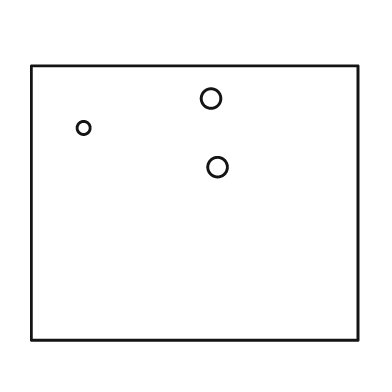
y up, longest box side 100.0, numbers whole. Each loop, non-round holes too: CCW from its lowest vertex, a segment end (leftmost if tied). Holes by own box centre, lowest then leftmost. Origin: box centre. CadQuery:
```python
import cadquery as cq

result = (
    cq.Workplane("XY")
    .moveTo(-50.0, -42.0)
    .lineTo(50.0, -42.0)
    .lineTo(50.0, 42.0)
    .lineTo(-50.0, 42.0)
    .close()
    .moveTo(7.0, 11.0)
    .circle(3.0)
    .moveTo(-34.0, 23.0)
    .circle(2.0)
    .moveTo(5.0, 32.0)
    .circle(3.0)
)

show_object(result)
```